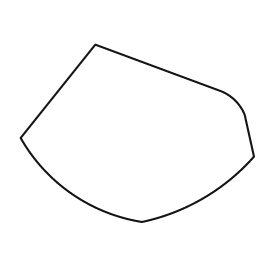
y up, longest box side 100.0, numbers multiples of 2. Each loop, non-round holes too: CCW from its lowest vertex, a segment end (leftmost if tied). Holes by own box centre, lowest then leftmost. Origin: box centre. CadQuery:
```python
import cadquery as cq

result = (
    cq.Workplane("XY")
    .moveTo(2.0, -38.0)
    .threePointArc((28.0, -28.0), (50.0, -10.0))
    .lineTo(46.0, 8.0)
    .threePointArc((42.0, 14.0), (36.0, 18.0))
    .lineTo(-18.0, 38.0)
    .lineTo(-50.0, -2.0)
    .threePointArc((-28.0, -26.0), (2.0, -38.0))
    .close()
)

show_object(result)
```